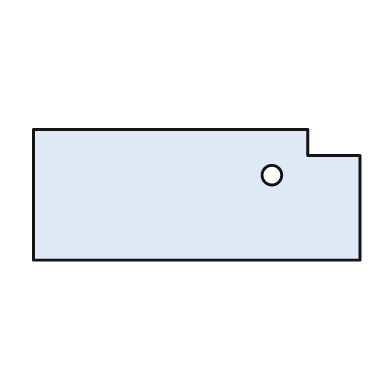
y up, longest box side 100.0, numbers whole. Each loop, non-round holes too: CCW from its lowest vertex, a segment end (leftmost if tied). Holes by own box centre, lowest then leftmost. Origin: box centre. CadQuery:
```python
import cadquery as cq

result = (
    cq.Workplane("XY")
    .moveTo(-50.0, -20.0)
    .lineTo(50.0, -20.0)
    .lineTo(50.0, 12.0)
    .lineTo(34.0, 12.0)
    .lineTo(34.0, 20.0)
    .lineTo(-50.0, 20.0)
    .close()
    .moveTo(23.0, 6.0)
    .circle(3.0)
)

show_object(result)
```